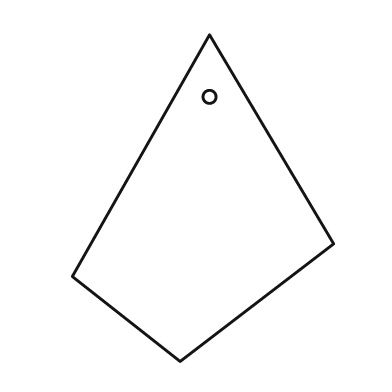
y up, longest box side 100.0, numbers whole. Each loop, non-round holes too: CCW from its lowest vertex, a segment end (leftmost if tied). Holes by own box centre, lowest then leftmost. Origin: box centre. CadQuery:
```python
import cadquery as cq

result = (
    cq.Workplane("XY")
    .moveTo(-7.0, -50.0)
    .lineTo(40.0, -14.0)
    .lineTo(2.0, 50.0)
    .lineTo(-40.0, -24.0)
    .close()
    .moveTo(2.0, 31.0)
    .circle(2.0)
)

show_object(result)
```